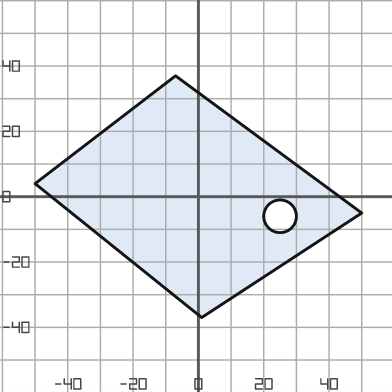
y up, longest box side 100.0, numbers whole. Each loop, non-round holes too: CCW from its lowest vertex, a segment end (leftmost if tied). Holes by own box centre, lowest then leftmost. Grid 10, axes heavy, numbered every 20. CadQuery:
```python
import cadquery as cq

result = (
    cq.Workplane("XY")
    .moveTo(1.0, -37.0)
    .lineTo(50.0, -5.0)
    .lineTo(-7.0, 37.0)
    .lineTo(-50.0, 4.0)
    .close()
    .moveTo(25.0, -6.0)
    .circle(5.0)
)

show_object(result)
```